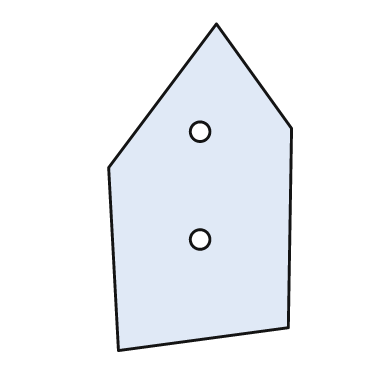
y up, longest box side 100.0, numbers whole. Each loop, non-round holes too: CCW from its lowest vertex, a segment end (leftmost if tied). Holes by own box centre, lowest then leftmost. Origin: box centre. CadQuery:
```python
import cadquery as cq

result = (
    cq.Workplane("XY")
    .moveTo(-25.0, -50.0)
    .lineTo(27.0, -43.0)
    .lineTo(28.0, 18.0)
    .lineTo(5.0, 50.0)
    .lineTo(-28.0, 6.0)
    .close()
    .moveTo(0.0, -16.0)
    .circle(3.0)
    .moveTo(0.0, 17.0)
    .circle(3.0)
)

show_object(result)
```